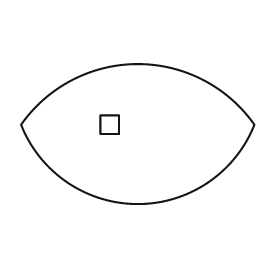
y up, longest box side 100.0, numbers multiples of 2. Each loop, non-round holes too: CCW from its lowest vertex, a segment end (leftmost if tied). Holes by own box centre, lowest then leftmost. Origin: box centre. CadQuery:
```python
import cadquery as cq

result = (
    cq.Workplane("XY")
    .moveTo(-50.0, 4.0)
    .threePointArc((0.0, -30.0), (50.0, 4.0))
    .threePointArc((0.0, 30.0), (-50.0, 4.0))
    .close()
    .moveTo(-16.0, 0.0)
    .lineTo(-8.0, 0.0)
    .lineTo(-8.0, 8.0)
    .lineTo(-16.0, 8.0)
    .close()
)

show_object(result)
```